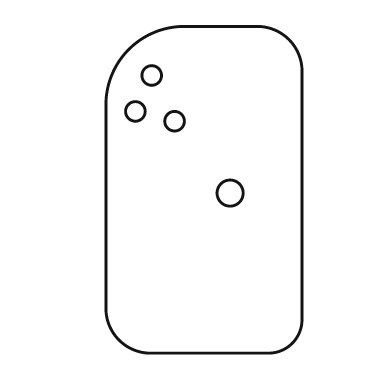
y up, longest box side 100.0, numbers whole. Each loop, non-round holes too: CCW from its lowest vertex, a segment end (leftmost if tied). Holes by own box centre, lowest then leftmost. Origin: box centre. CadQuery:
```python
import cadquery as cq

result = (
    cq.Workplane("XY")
    .moveTo(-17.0, -50.0)
    .lineTo(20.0, -50.0)
    .threePointArc((27.0, -47.0), (30.0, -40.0))
    .lineTo(30.0, 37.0)
    .threePointArc((26.0, 46.0), (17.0, 50.0))
    .lineTo(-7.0, 50.0)
    .threePointArc((-23.0, 43.0), (-30.0, 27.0))
    .lineTo(-30.0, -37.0)
    .threePointArc((-26.0, -46.0), (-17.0, -50.0))
    .close()
    .moveTo(8.0, -1.0)
    .circle(4.0)
    .moveTo(-9.0, 21.0)
    .circle(3.0)
    .moveTo(-21.0, 24.0)
    .circle(3.0)
    .moveTo(-16.0, 35.0)
    .circle(3.0)
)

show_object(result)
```